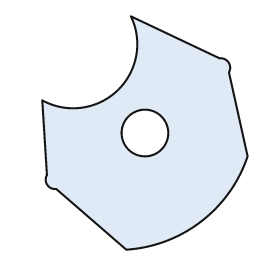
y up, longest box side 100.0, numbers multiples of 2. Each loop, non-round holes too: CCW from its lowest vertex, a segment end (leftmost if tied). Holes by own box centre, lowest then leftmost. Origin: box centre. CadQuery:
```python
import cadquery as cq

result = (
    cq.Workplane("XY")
    .moveTo(-8.0, -50.0)
    .threePointArc((24.0, -38.0), (44.0, -10.0))
    .lineTo(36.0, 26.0)
    .threePointArc((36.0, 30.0), (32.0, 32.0))
    .lineTo(-6.0, 50.0)
    .threePointArc((-12.0, 18.0), (-44.0, 14.0))
    .lineTo(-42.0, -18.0)
    .threePointArc((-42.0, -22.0), (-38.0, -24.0))
    .close()
    .moveTo(0.0, 0.0)
    .circle(10.0)
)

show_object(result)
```